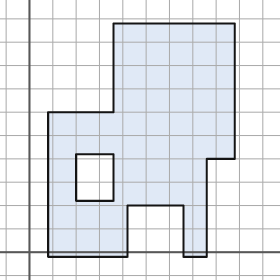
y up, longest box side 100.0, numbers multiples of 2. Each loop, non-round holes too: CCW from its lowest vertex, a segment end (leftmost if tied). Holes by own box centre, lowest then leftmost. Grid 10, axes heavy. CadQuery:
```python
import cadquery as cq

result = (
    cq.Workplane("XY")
    .moveTo(8.0, -2.0)
    .lineTo(42.0, -2.0)
    .lineTo(42.0, 20.0)
    .lineTo(66.0, 20.0)
    .lineTo(66.0, -2.0)
    .lineTo(76.0, -2.0)
    .lineTo(76.0, 40.0)
    .lineTo(88.0, 40.0)
    .lineTo(88.0, 98.0)
    .lineTo(36.0, 98.0)
    .lineTo(36.0, 60.0)
    .lineTo(8.0, 60.0)
    .close()
    .moveTo(20.0, 22.0)
    .lineTo(36.0, 22.0)
    .lineTo(36.0, 42.0)
    .lineTo(20.0, 42.0)
    .close()
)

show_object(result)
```